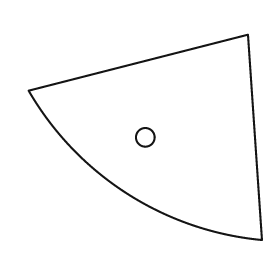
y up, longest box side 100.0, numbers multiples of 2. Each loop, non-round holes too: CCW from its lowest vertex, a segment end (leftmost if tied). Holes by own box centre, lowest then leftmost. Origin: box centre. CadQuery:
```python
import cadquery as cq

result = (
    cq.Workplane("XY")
    .moveTo(50.0, -44.0)
    .lineTo(44.0, 44.0)
    .lineTo(-50.0, 20.0)
    .threePointArc((-8.0, -24.0), (50.0, -44.0))
    .close()
    .moveTo(0.0, 0.0)
    .circle(4.0)
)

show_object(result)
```